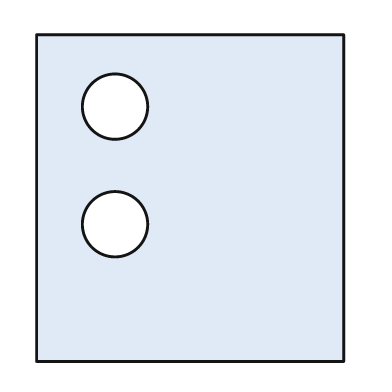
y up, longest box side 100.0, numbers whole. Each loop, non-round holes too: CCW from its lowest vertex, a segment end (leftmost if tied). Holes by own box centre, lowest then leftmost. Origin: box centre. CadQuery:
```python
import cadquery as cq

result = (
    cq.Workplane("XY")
    .moveTo(-47.0, -50.0)
    .lineTo(47.0, -50.0)
    .lineTo(47.0, 50.0)
    .lineTo(-47.0, 50.0)
    .close()
    .moveTo(-23.0, -8.0)
    .circle(10.0)
    .moveTo(-23.0, 28.0)
    .circle(10.0)
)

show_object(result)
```